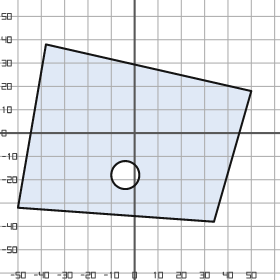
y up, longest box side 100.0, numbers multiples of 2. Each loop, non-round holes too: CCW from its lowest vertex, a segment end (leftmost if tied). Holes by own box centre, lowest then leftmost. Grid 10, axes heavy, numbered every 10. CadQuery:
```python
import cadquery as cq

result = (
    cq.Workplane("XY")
    .moveTo(34.0, -38.0)
    .lineTo(50.0, 18.0)
    .lineTo(-38.0, 38.0)
    .lineTo(-50.0, -32.0)
    .close()
    .moveTo(-4.0, -18.0)
    .circle(6.0)
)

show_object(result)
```